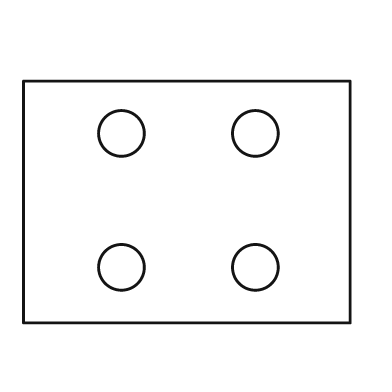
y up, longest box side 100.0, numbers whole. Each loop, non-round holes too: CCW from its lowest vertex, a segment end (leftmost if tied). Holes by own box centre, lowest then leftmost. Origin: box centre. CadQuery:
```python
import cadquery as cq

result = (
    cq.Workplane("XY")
    .moveTo(-50.0, -37.0)
    .lineTo(50.0, -37.0)
    .lineTo(50.0, 37.0)
    .lineTo(-50.0, 37.0)
    .close()
    .moveTo(-20.0, -20.0)
    .circle(7.0)
    .moveTo(21.0, -20.0)
    .circle(7.0)
    .moveTo(-20.0, 21.0)
    .circle(7.0)
    .moveTo(21.0, 21.0)
    .circle(7.0)
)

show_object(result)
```